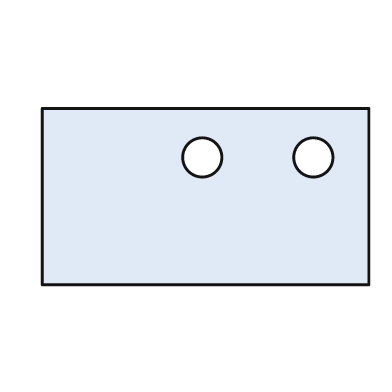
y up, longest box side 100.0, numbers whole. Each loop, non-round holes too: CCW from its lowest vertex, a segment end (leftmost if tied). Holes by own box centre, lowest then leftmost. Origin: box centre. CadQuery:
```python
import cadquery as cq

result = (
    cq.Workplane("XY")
    .moveTo(-50.0, -27.0)
    .lineTo(50.0, -27.0)
    .lineTo(50.0, 27.0)
    .lineTo(-50.0, 27.0)
    .close()
    .moveTo(-1.0, 12.0)
    .circle(6.0)
    .moveTo(33.0, 12.0)
    .circle(6.0)
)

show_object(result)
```